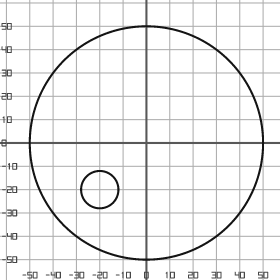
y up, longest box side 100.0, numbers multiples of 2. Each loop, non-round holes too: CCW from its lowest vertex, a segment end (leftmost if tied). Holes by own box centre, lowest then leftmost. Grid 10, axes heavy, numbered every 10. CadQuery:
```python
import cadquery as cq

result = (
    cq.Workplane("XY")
    .moveTo(0.0, 0.0)
    .circle(50.0)
    .moveTo(-20.0, -20.0)
    .circle(8.0)
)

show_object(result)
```